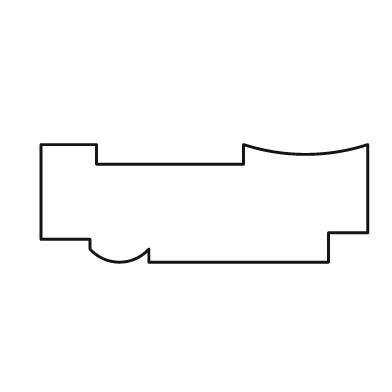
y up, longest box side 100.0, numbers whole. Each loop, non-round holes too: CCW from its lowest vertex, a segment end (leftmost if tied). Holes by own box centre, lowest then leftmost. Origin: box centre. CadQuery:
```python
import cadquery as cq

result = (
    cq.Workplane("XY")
    .moveTo(-17.0, -18.0)
    .lineTo(38.0, -18.0)
    .lineTo(38.0, -9.0)
    .lineTo(50.0, -9.0)
    .lineTo(50.0, 18.0)
    .threePointArc((31.0, 15.0), (12.0, 18.0))
    .lineTo(12.0, 12.0)
    .lineTo(-33.0, 12.0)
    .lineTo(-33.0, 18.0)
    .lineTo(-50.0, 18.0)
    .lineTo(-50.0, -11.0)
    .lineTo(-35.0, -11.0)
    .lineTo(-35.0, -14.0)
    .threePointArc((-26.0, -18.0), (-17.0, -14.0))
    .close()
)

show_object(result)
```